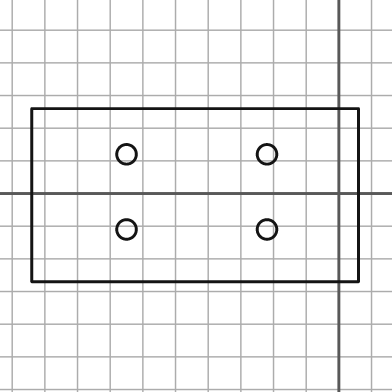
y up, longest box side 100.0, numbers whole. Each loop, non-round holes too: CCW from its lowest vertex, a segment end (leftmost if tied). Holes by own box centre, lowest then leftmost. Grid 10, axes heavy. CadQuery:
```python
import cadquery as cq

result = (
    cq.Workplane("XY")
    .moveTo(-94.0, -27.0)
    .lineTo(6.0, -27.0)
    .lineTo(6.0, 26.0)
    .lineTo(-94.0, 26.0)
    .close()
    .moveTo(-65.0, -11.0)
    .circle(3.0)
    .moveTo(-22.0, -11.0)
    .circle(3.0)
    .moveTo(-65.0, 12.0)
    .circle(3.0)
    .moveTo(-22.0, 12.0)
    .circle(3.0)
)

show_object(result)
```